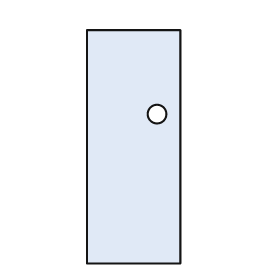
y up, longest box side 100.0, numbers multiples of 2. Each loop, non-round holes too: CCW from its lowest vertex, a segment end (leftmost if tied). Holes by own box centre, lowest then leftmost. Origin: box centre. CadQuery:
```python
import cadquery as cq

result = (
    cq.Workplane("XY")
    .moveTo(-20.0, -50.0)
    .lineTo(20.0, -50.0)
    .lineTo(20.0, 50.0)
    .lineTo(-20.0, 50.0)
    .close()
    .moveTo(10.0, 14.0)
    .circle(4.0)
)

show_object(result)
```